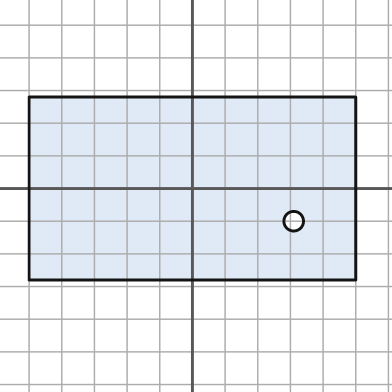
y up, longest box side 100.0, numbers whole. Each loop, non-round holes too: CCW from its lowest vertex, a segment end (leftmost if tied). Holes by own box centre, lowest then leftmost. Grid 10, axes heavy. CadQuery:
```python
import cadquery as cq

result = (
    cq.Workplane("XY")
    .moveTo(-50.0, -28.0)
    .lineTo(50.0, -28.0)
    .lineTo(50.0, 28.0)
    .lineTo(-50.0, 28.0)
    .close()
    .moveTo(31.0, -10.0)
    .circle(3.0)
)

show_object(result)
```